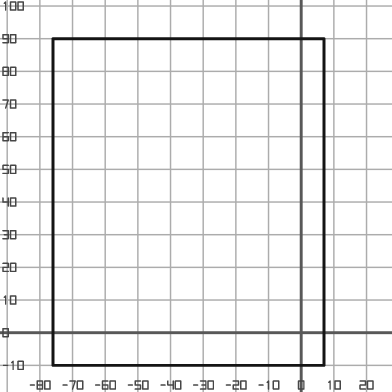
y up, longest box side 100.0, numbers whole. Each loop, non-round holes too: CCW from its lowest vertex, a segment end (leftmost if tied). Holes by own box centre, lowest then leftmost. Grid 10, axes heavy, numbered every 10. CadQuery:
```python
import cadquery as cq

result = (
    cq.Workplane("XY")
    .moveTo(-76.0, -10.0)
    .lineTo(7.0, -10.0)
    .lineTo(7.0, 90.0)
    .lineTo(-76.0, 90.0)
    .close()
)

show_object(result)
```